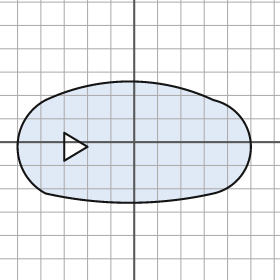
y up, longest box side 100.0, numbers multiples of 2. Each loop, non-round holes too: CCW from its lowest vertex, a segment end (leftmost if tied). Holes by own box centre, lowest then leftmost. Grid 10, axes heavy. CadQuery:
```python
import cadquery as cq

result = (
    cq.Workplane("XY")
    .moveTo(-38.0, -22.0)
    .threePointArc((-2.0, -26.0), (34.0, -22.0))
    .threePointArc((50.0, -2.0), (34.0, 18.0))
    .threePointArc((-2.0, 26.0), (-38.0, 18.0))
    .threePointArc((-50.0, -2.0), (-38.0, -22.0))
    .close()
    .moveTo(-30.0, -8.0)
    .lineTo(-20.0, -2.0)
    .lineTo(-30.0, 4.0)
    .close()
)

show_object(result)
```